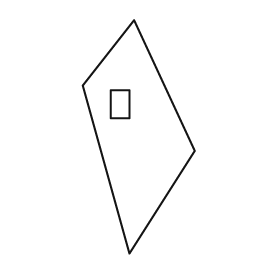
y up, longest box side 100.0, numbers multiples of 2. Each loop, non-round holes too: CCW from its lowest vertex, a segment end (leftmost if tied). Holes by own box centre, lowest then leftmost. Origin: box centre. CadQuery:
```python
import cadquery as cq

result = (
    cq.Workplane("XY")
    .moveTo(-4.0, -50.0)
    .lineTo(24.0, -6.0)
    .lineTo(-2.0, 50.0)
    .lineTo(-24.0, 22.0)
    .close()
    .moveTo(-12.0, 8.0)
    .lineTo(-4.0, 8.0)
    .lineTo(-4.0, 20.0)
    .lineTo(-12.0, 20.0)
    .close()
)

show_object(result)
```